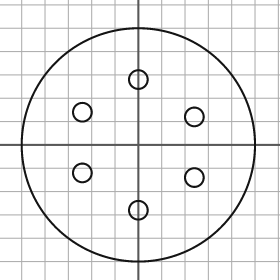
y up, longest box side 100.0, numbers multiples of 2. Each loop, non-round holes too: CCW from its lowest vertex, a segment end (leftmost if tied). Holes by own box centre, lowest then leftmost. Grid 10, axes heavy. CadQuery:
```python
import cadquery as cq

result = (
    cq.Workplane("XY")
    .moveTo(0.0, 0.0)
    .circle(50.0)
    .moveTo(0.0, -28.0)
    .circle(4.0)
    .moveTo(24.0, -14.0)
    .circle(4.0)
    .moveTo(-24.0, -12.0)
    .circle(4.0)
    .moveTo(24.0, 12.0)
    .circle(4.0)
    .moveTo(-24.0, 14.0)
    .circle(4.0)
    .moveTo(0.0, 28.0)
    .circle(4.0)
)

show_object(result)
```